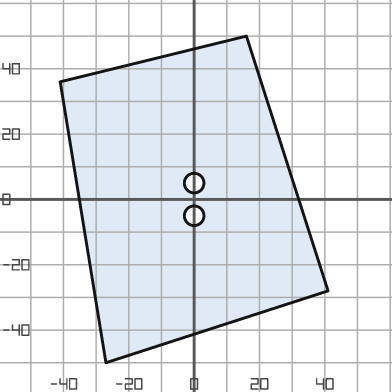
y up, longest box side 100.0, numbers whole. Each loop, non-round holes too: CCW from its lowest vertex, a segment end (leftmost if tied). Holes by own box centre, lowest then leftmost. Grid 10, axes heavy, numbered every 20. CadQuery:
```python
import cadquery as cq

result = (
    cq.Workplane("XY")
    .moveTo(-27.0, -50.0)
    .lineTo(41.0, -28.0)
    .lineTo(16.0, 50.0)
    .lineTo(-41.0, 36.0)
    .close()
    .moveTo(0.0, -5.0)
    .circle(3.0)
    .moveTo(0.0, 5.0)
    .circle(3.0)
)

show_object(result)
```